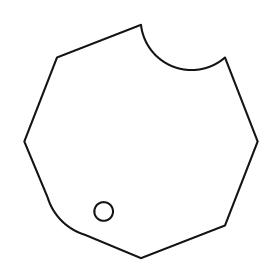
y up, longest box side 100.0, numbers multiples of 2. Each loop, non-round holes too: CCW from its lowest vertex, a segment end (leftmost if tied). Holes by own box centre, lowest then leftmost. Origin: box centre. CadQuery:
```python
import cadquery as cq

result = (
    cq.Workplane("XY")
    .moveTo(0.0, -50.0)
    .lineTo(36.0, -36.0)
    .lineTo(50.0, 0.0)
    .lineTo(36.0, 36.0)
    .threePointArc((14.0, 32.0), (0.0, 50.0))
    .lineTo(-36.0, 36.0)
    .lineTo(-50.0, 0.0)
    .lineTo(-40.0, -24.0)
    .threePointArc((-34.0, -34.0), (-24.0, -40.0))
    .close()
    .moveTo(-16.0, -30.0)
    .circle(4.0)
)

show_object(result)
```